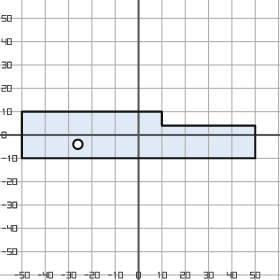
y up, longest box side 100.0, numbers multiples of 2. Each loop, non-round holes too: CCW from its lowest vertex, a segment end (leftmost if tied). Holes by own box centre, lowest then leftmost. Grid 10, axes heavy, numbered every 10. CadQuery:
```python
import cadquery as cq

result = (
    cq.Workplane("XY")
    .moveTo(-50.0, -10.0)
    .lineTo(50.0, -10.0)
    .lineTo(50.0, 4.0)
    .lineTo(10.0, 4.0)
    .lineTo(10.0, 10.0)
    .lineTo(-50.0, 10.0)
    .close()
    .moveTo(-26.0, -4.0)
    .circle(2.0)
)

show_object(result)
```